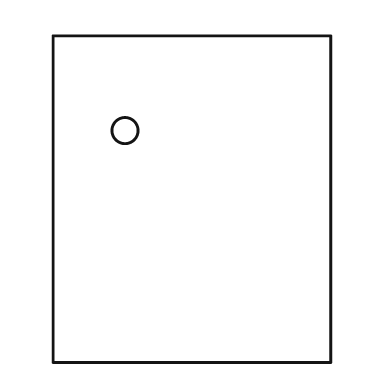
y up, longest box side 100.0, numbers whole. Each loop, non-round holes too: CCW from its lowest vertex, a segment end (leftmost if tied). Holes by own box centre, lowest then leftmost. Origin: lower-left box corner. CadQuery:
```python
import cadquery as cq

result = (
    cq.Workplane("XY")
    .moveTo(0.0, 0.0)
    .lineTo(85.0, 0.0)
    .lineTo(85.0, 100.0)
    .lineTo(0.0, 100.0)
    .close()
    .moveTo(22.0, 71.0)
    .circle(4.0)
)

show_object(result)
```